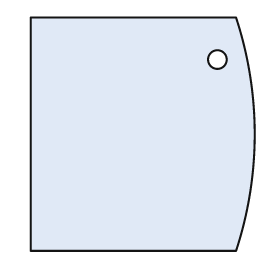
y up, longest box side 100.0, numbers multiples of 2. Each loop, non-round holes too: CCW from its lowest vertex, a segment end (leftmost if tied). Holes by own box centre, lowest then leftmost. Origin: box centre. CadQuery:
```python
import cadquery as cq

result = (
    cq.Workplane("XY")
    .moveTo(-48.0, -50.0)
    .lineTo(40.0, -50.0)
    .threePointArc((48.0, 0.0), (40.0, 50.0))
    .lineTo(-48.0, 50.0)
    .close()
    .moveTo(32.0, 32.0)
    .circle(4.0)
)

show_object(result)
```